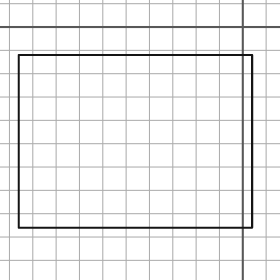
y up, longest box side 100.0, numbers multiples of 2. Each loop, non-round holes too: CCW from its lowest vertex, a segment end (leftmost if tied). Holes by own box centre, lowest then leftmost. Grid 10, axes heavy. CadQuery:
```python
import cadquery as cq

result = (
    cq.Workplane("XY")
    .moveTo(-96.0, -86.0)
    .lineTo(4.0, -86.0)
    .lineTo(4.0, -12.0)
    .lineTo(-96.0, -12.0)
    .close()
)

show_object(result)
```